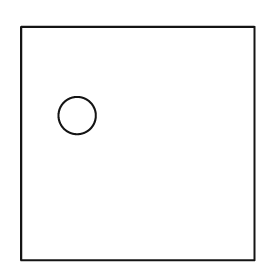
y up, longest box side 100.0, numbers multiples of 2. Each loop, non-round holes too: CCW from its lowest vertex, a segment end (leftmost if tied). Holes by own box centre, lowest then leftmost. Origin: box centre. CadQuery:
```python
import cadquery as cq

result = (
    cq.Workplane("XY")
    .moveTo(-50.0, -50.0)
    .lineTo(50.0, -50.0)
    .lineTo(50.0, 50.0)
    .lineTo(-50.0, 50.0)
    .close()
    .moveTo(-26.0, 12.0)
    .circle(8.0)
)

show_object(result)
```